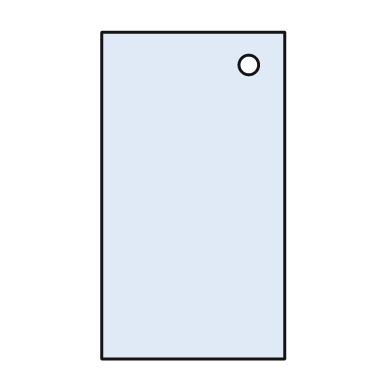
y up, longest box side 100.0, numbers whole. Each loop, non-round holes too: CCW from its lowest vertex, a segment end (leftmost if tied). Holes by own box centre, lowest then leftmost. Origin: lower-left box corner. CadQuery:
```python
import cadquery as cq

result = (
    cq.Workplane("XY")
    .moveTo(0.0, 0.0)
    .lineTo(56.0, 0.0)
    .lineTo(56.0, 100.0)
    .lineTo(0.0, 100.0)
    .close()
    .moveTo(45.0, 90.0)
    .circle(3.0)
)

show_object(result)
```